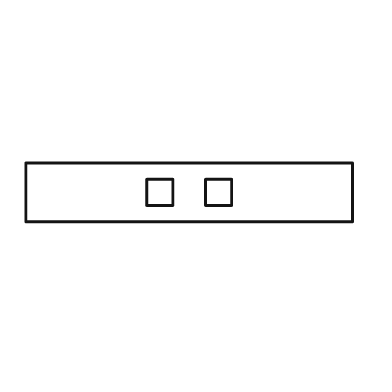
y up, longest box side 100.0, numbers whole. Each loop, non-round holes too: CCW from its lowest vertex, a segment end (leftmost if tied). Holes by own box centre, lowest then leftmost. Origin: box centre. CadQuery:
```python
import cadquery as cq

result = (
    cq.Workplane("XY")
    .moveTo(-50.0, -9.0)
    .lineTo(50.0, -9.0)
    .lineTo(50.0, 9.0)
    .lineTo(-50.0, 9.0)
    .close()
    .moveTo(-13.0, -4.0)
    .lineTo(-5.0, -4.0)
    .lineTo(-5.0, 4.0)
    .lineTo(-13.0, 4.0)
    .close()
    .moveTo(5.0, -4.0)
    .lineTo(13.0, -4.0)
    .lineTo(13.0, 4.0)
    .lineTo(5.0, 4.0)
    .close()
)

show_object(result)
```